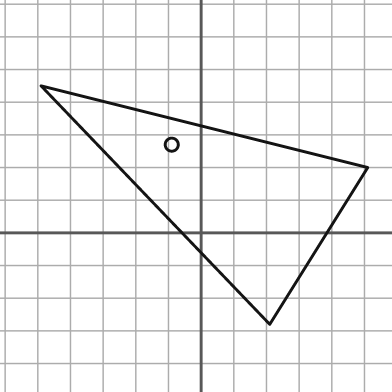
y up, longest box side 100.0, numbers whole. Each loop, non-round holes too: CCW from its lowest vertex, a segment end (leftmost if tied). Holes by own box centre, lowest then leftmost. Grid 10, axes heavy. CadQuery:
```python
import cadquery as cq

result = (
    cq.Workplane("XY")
    .moveTo(21.0, -28.0)
    .lineTo(51.0, 20.0)
    .lineTo(-49.0, 45.0)
    .close()
    .moveTo(-9.0, 27.0)
    .circle(2.0)
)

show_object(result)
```